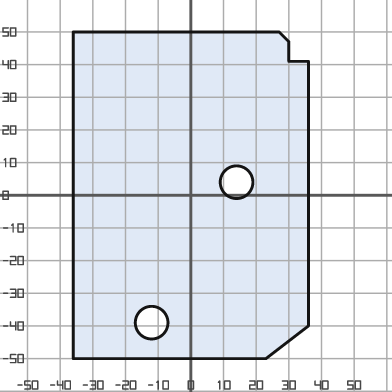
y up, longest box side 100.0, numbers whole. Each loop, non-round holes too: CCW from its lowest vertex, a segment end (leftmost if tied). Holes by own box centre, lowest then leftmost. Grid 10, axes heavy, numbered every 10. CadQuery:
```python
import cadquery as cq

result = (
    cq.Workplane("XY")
    .moveTo(-36.0, -50.0)
    .lineTo(23.0, -50.0)
    .lineTo(36.0, -40.0)
    .lineTo(36.0, 41.0)
    .lineTo(30.0, 41.0)
    .lineTo(30.0, 47.0)
    .lineTo(27.0, 50.0)
    .lineTo(-36.0, 50.0)
    .close()
    .moveTo(-12.0, -39.0)
    .circle(5.0)
    .moveTo(14.0, 4.0)
    .circle(5.0)
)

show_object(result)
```